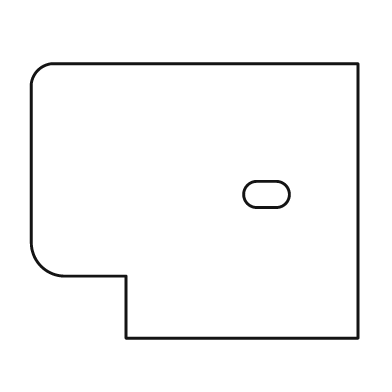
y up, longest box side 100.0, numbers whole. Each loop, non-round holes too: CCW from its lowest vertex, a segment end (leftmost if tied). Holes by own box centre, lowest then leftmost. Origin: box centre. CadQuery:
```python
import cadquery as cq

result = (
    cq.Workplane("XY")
    .moveTo(-21.0, -42.0)
    .lineTo(50.0, -42.0)
    .lineTo(50.0, 42.0)
    .lineTo(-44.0, 42.0)
    .threePointArc((-48.0, 40.0), (-50.0, 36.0))
    .lineTo(-50.0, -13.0)
    .threePointArc((-47.0, -20.0), (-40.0, -23.0))
    .lineTo(-21.0, -23.0)
    .close()
    .moveTo(19.0, -2.0)
    .lineTo(25.0, -2.0)
    .threePointArc((29.0, 2.0), (25.0, 6.0))
    .lineTo(19.0, 6.0)
    .threePointArc((15.0, 2.0), (19.0, -2.0))
    .close()
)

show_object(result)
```